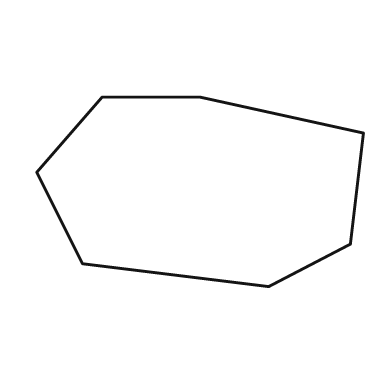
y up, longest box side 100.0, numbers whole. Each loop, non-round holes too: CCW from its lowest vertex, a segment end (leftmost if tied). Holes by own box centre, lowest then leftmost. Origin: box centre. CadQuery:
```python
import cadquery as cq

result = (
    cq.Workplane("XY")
    .moveTo(21.0, -29.0)
    .lineTo(46.0, -16.0)
    .lineTo(50.0, 18.0)
    .lineTo(0.0, 29.0)
    .lineTo(-30.0, 29.0)
    .lineTo(-50.0, 6.0)
    .lineTo(-36.0, -22.0)
    .close()
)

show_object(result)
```